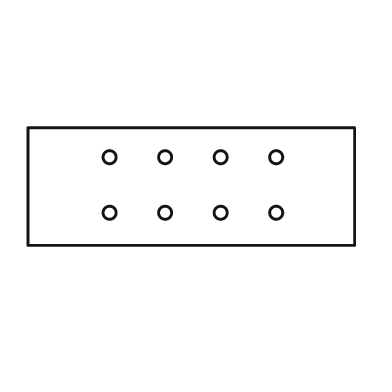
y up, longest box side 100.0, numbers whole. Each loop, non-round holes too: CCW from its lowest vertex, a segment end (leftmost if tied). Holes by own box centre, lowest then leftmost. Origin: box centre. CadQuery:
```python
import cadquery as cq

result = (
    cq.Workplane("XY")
    .moveTo(-50.0, -18.0)
    .lineTo(50.0, -18.0)
    .lineTo(50.0, 18.0)
    .lineTo(-50.0, 18.0)
    .close()
    .moveTo(-25.0, -8.0)
    .circle(2.0)
    .moveTo(-8.0, -8.0)
    .circle(2.0)
    .moveTo(9.0, -8.0)
    .circle(2.0)
    .moveTo(26.0, -8.0)
    .circle(2.0)
    .moveTo(-25.0, 9.0)
    .circle(2.0)
    .moveTo(-8.0, 9.0)
    .circle(2.0)
    .moveTo(9.0, 9.0)
    .circle(2.0)
    .moveTo(26.0, 9.0)
    .circle(2.0)
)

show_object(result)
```